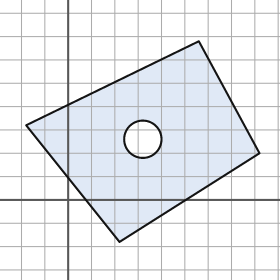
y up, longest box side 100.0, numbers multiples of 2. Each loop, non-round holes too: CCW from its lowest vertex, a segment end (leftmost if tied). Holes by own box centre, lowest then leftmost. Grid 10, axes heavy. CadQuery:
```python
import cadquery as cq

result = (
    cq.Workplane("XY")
    .moveTo(22.0, -18.0)
    .lineTo(82.0, 20.0)
    .lineTo(56.0, 68.0)
    .lineTo(-18.0, 32.0)
    .close()
    .moveTo(32.0, 26.0)
    .circle(8.0)
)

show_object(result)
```